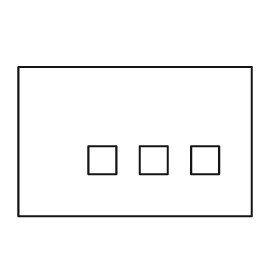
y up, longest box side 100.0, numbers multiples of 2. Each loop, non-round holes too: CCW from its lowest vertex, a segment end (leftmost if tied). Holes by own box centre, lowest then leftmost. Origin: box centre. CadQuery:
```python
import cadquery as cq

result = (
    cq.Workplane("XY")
    .moveTo(-50.0, -32.0)
    .lineTo(50.0, -32.0)
    .lineTo(50.0, 32.0)
    .lineTo(-50.0, 32.0)
    .close()
    .moveTo(-20.0, -14.0)
    .lineTo(-8.0, -14.0)
    .lineTo(-8.0, -2.0)
    .lineTo(-20.0, -2.0)
    .close()
    .moveTo(2.0, -14.0)
    .lineTo(14.0, -14.0)
    .lineTo(14.0, -2.0)
    .lineTo(2.0, -2.0)
    .close()
    .moveTo(24.0, -14.0)
    .lineTo(36.0, -14.0)
    .lineTo(36.0, -2.0)
    .lineTo(24.0, -2.0)
    .close()
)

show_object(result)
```